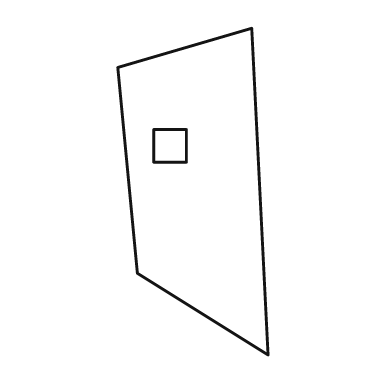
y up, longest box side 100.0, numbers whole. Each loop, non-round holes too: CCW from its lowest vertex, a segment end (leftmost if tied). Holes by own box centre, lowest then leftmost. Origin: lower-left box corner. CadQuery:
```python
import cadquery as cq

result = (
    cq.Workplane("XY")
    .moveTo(46.0, 0.0)
    .lineTo(41.0, 100.0)
    .lineTo(0.0, 88.0)
    .lineTo(6.0, 25.0)
    .close()
    .moveTo(11.0, 59.0)
    .lineTo(21.0, 59.0)
    .lineTo(21.0, 69.0)
    .lineTo(11.0, 69.0)
    .close()
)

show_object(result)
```